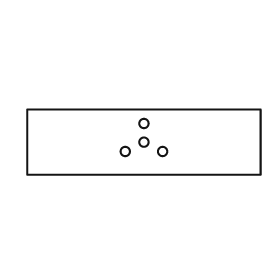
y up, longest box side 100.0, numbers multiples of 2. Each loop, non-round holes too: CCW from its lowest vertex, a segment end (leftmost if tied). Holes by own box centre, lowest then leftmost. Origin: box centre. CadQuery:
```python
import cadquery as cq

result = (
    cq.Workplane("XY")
    .moveTo(-50.0, -14.0)
    .lineTo(50.0, -14.0)
    .lineTo(50.0, 14.0)
    .lineTo(-50.0, 14.0)
    .close()
    .moveTo(-8.0, -4.0)
    .circle(2.0)
    .moveTo(8.0, -4.0)
    .circle(2.0)
    .moveTo(0.0, 0.0)
    .circle(2.0)
    .moveTo(0.0, 8.0)
    .circle(2.0)
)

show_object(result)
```